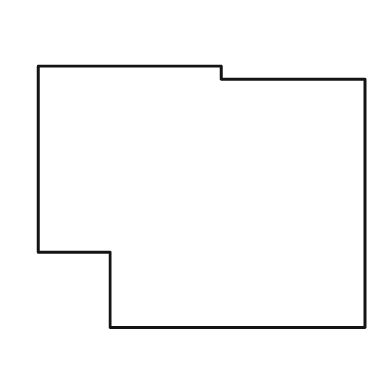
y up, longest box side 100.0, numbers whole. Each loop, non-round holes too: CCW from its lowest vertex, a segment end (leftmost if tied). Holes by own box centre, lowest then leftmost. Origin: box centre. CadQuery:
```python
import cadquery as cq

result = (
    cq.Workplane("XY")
    .moveTo(-28.0, -40.0)
    .lineTo(50.0, -40.0)
    .lineTo(50.0, 36.0)
    .lineTo(6.0, 36.0)
    .lineTo(6.0, 40.0)
    .lineTo(-50.0, 40.0)
    .lineTo(-50.0, -17.0)
    .lineTo(-28.0, -17.0)
    .close()
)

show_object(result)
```